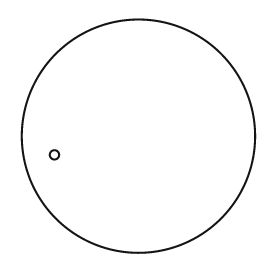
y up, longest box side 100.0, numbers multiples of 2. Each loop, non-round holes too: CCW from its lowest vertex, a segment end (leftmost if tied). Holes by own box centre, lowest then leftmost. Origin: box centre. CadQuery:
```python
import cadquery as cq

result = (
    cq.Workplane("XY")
    .moveTo(0.0, 0.0)
    .circle(50.0)
    .moveTo(-36.0, -8.0)
    .circle(2.0)
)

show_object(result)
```